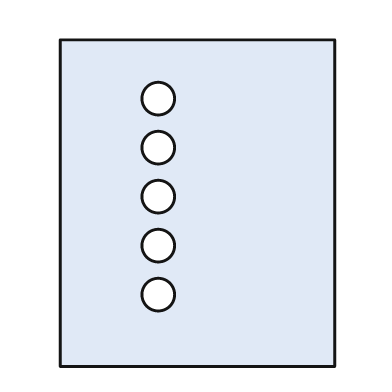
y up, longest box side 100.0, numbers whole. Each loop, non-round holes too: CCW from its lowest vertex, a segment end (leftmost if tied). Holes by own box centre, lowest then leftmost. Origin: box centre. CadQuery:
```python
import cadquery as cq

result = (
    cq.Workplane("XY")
    .moveTo(-42.0, -50.0)
    .lineTo(42.0, -50.0)
    .lineTo(42.0, 50.0)
    .lineTo(-42.0, 50.0)
    .close()
    .moveTo(-12.0, -28.0)
    .circle(5.0)
    .moveTo(-12.0, -13.0)
    .circle(5.0)
    .moveTo(-12.0, 2.0)
    .circle(5.0)
    .moveTo(-12.0, 17.0)
    .circle(5.0)
    .moveTo(-12.0, 32.0)
    .circle(5.0)
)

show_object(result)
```